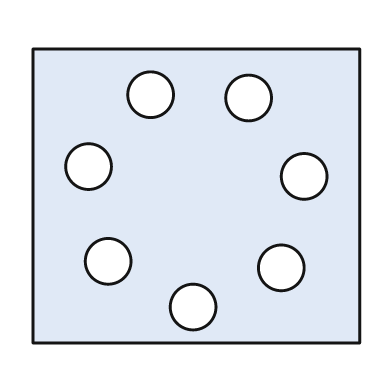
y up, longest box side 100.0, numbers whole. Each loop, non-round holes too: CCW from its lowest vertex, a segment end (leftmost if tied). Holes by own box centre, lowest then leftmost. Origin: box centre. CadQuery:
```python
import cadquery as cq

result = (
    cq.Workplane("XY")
    .moveTo(-50.0, -45.0)
    .lineTo(50.0, -45.0)
    .lineTo(50.0, 45.0)
    .lineTo(-50.0, 45.0)
    .close()
    .moveTo(-1.0, -34.0)
    .circle(7.0)
    .moveTo(26.0, -22.0)
    .circle(7.0)
    .moveTo(-27.0, -20.0)
    .circle(7.0)
    .moveTo(33.0, 6.0)
    .circle(7.0)
    .moveTo(-33.0, 9.0)
    .circle(7.0)
    .moveTo(16.0, 30.0)
    .circle(7.0)
    .moveTo(-14.0, 31.0)
    .circle(7.0)
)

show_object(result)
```